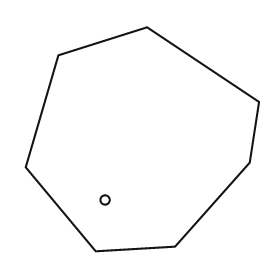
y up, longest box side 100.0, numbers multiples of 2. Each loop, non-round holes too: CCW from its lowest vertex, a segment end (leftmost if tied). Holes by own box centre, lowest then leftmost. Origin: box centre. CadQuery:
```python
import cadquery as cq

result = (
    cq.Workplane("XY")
    .moveTo(-20.0, -48.0)
    .lineTo(14.0, -46.0)
    .lineTo(46.0, -10.0)
    .lineTo(50.0, 16.0)
    .lineTo(2.0, 48.0)
    .lineTo(-36.0, 36.0)
    .lineTo(-50.0, -12.0)
    .close()
    .moveTo(-16.0, -26.0)
    .circle(2.0)
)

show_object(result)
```